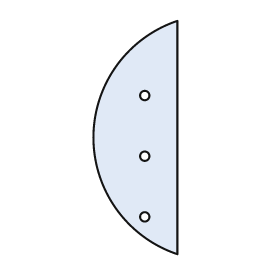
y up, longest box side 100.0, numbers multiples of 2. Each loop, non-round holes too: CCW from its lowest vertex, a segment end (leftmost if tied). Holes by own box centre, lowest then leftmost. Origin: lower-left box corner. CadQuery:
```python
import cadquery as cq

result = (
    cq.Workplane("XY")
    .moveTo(36.0, 0.0)
    .lineTo(36.0, 100.0)
    .threePointArc((0.0, 50.0), (36.0, 0.0))
    .close()
    .moveTo(22.0, 16.0)
    .circle(2.0)
    .moveTo(22.0, 42.0)
    .circle(2.0)
    .moveTo(22.0, 68.0)
    .circle(2.0)
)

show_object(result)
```